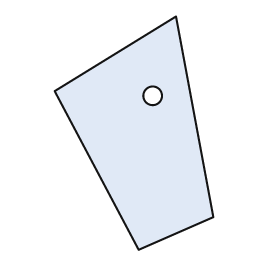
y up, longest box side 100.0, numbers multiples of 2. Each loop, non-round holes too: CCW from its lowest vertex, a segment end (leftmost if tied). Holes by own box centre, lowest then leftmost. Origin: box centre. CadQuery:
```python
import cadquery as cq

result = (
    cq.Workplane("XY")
    .moveTo(2.0, -50.0)
    .lineTo(34.0, -36.0)
    .lineTo(18.0, 50.0)
    .lineTo(-34.0, 18.0)
    .close()
    .moveTo(8.0, 16.0)
    .circle(4.0)
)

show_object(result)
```